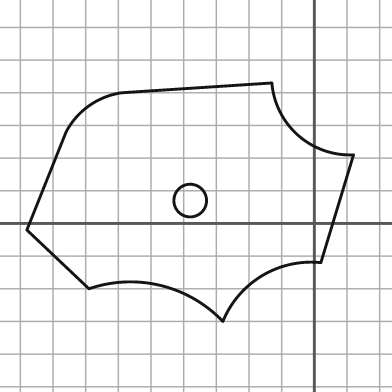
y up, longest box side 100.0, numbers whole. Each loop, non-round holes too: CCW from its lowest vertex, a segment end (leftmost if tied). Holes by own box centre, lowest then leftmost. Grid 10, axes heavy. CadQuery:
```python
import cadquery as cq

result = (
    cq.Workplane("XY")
    .moveTo(-28.0, -30.0)
    .threePointArc((-16.0, -16.0), (2.0, -12.0))
    .lineTo(12.0, 21.0)
    .threePointArc((-5.0, 27.0), (-13.0, 43.0))
    .lineTo(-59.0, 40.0)
    .threePointArc((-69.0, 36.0), (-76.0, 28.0))
    .lineTo(-88.0, -2.0)
    .lineTo(-69.0, -20.0)
    .threePointArc((-47.0, -19.0), (-28.0, -30.0))
    .close()
    .moveTo(-38.0, 7.0)
    .circle(5.0)
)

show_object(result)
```